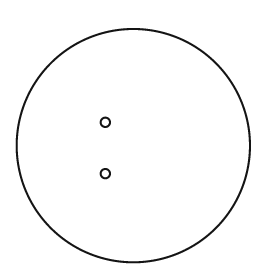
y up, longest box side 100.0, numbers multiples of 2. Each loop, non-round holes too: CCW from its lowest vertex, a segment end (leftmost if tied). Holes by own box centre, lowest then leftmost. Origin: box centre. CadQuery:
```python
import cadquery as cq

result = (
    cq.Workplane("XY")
    .moveTo(0.0, 0.0)
    .circle(50.0)
    .moveTo(-12.0, -12.0)
    .circle(2.0)
    .moveTo(-12.0, 10.0)
    .circle(2.0)
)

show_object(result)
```